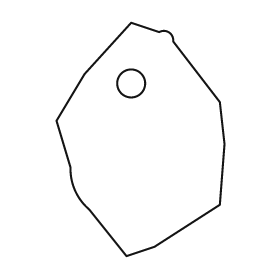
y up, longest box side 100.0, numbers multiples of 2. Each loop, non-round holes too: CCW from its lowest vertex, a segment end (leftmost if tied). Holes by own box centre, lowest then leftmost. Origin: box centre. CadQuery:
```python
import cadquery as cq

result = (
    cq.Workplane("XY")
    .moveTo(-6.0, -50.0)
    .lineTo(6.0, -46.0)
    .lineTo(34.0, -28.0)
    .lineTo(36.0, -2.0)
    .lineTo(34.0, 16.0)
    .lineTo(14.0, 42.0)
    .threePointArc((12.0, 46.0), (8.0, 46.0))
    .lineTo(-4.0, 50.0)
    .lineTo(-24.0, 28.0)
    .lineTo(-36.0, 8.0)
    .lineTo(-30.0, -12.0)
    .threePointArc((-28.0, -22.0), (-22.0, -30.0))
    .close()
    .moveTo(-4.0, 24.0)
    .circle(6.0)
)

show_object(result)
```